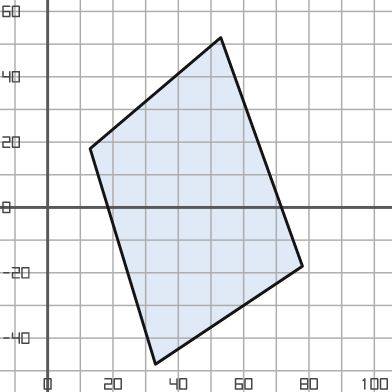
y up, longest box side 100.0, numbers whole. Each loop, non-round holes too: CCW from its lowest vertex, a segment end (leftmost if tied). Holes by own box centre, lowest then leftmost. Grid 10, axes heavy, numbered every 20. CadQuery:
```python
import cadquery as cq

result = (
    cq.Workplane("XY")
    .moveTo(33.0, -48.0)
    .lineTo(78.0, -18.0)
    .lineTo(53.0, 52.0)
    .lineTo(13.0, 18.0)
    .close()
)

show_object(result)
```